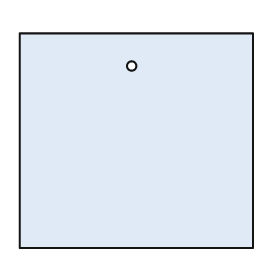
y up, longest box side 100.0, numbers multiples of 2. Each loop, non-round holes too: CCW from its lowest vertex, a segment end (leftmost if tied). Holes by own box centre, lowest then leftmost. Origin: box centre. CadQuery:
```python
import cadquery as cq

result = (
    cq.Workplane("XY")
    .moveTo(-50.0, -46.0)
    .lineTo(50.0, -46.0)
    .lineTo(50.0, 46.0)
    .lineTo(-50.0, 46.0)
    .close()
    .moveTo(-2.0, 32.0)
    .circle(2.0)
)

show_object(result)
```